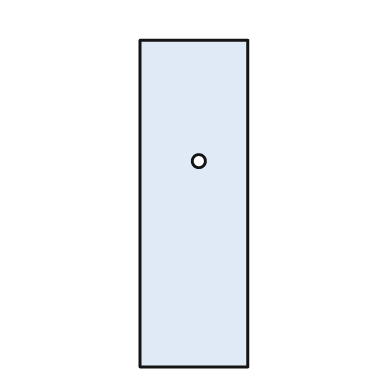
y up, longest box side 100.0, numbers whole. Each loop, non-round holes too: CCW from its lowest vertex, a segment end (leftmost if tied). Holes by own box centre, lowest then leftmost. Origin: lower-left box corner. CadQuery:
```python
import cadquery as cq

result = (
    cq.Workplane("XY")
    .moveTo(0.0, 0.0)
    .lineTo(33.0, 0.0)
    .lineTo(33.0, 100.0)
    .lineTo(0.0, 100.0)
    .close()
    .moveTo(18.0, 63.0)
    .circle(2.0)
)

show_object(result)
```